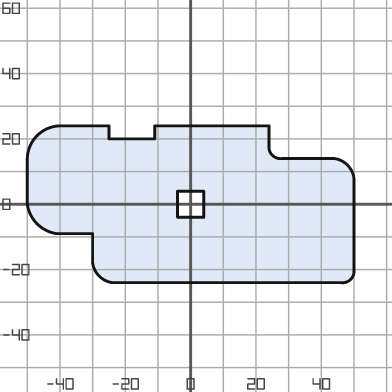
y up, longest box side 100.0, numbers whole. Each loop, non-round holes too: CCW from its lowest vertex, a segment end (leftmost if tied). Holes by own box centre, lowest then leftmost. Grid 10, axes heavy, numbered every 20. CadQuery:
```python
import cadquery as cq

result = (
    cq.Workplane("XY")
    .moveTo(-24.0, -24.0)
    .lineTo(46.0, -24.0)
    .threePointArc((49.0, -23.0), (50.0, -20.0))
    .lineTo(50.0, 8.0)
    .threePointArc((48.0, 12.0), (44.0, 14.0))
    .lineTo(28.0, 14.0)
    .threePointArc((25.0, 15.0), (24.0, 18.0))
    .lineTo(24.0, 24.0)
    .lineTo(-11.0, 24.0)
    .lineTo(-11.0, 20.0)
    .lineTo(-25.0, 20.0)
    .lineTo(-25.0, 24.0)
    .lineTo(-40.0, 24.0)
    .threePointArc((-47.0, 21.0), (-50.0, 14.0))
    .lineTo(-50.0, 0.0)
    .threePointArc((-47.0, -6.0), (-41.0, -9.0))
    .lineTo(-30.0, -9.0)
    .lineTo(-30.0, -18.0)
    .threePointArc((-28.0, -22.0), (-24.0, -24.0))
    .close()
    .moveTo(-4.0, -4.0)
    .lineTo(4.0, -4.0)
    .lineTo(4.0, 4.0)
    .lineTo(-4.0, 4.0)
    .close()
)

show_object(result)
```